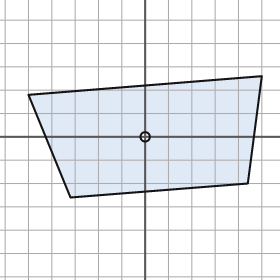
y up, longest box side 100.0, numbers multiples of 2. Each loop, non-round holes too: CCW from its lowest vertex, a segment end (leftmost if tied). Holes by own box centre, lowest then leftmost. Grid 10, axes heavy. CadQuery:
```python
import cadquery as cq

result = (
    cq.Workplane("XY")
    .moveTo(-32.0, -26.0)
    .lineTo(44.0, -20.0)
    .lineTo(50.0, 26.0)
    .lineTo(-50.0, 18.0)
    .close()
    .moveTo(0.0, 0.0)
    .circle(2.0)
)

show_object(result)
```